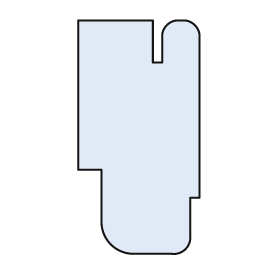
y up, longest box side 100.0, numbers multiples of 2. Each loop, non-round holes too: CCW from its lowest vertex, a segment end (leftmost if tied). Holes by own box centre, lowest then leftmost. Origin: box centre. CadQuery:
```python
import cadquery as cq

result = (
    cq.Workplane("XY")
    .moveTo(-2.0, -50.0)
    .lineTo(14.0, -50.0)
    .threePointArc((20.0, -48.0), (22.0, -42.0))
    .lineTo(22.0, -26.0)
    .lineTo(26.0, -26.0)
    .lineTo(26.0, 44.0)
    .threePointArc((24.0, 48.0), (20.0, 50.0))
    .lineTo(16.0, 50.0)
    .threePointArc((12.0, 48.0), (10.0, 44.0))
    .lineTo(10.0, 32.0)
    .lineTo(6.0, 32.0)
    .lineTo(6.0, 50.0)
    .lineTo(-26.0, 50.0)
    .lineTo(-26.0, -14.0)
    .lineTo(-16.0, -14.0)
    .lineTo(-16.0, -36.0)
    .threePointArc((-12.0, -46.0), (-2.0, -50.0))
    .close()
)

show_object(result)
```